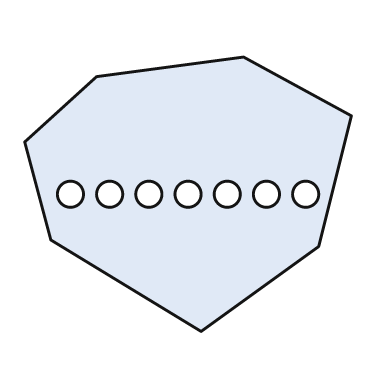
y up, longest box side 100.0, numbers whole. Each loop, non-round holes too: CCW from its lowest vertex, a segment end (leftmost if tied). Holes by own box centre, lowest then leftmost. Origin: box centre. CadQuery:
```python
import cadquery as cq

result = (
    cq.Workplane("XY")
    .moveTo(4.0, -42.0)
    .lineTo(40.0, -16.0)
    .lineTo(50.0, 24.0)
    .lineTo(17.0, 42.0)
    .lineTo(-28.0, 36.0)
    .lineTo(-50.0, 16.0)
    .lineTo(-42.0, -14.0)
    .close()
    .moveTo(-36.0, 0.0)
    .circle(4.0)
    .moveTo(-24.0, 0.0)
    .circle(4.0)
    .moveTo(-12.0, 0.0)
    .circle(4.0)
    .moveTo(0.0, 0.0)
    .circle(4.0)
    .moveTo(12.0, 0.0)
    .circle(4.0)
    .moveTo(24.0, 0.0)
    .circle(4.0)
    .moveTo(36.0, 0.0)
    .circle(4.0)
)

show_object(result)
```